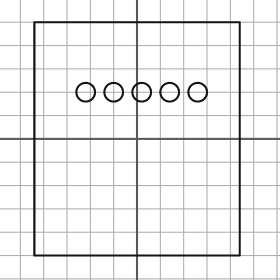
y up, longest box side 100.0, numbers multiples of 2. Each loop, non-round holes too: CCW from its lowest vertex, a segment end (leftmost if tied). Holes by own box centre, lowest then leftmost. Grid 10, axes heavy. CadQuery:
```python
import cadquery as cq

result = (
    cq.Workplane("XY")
    .moveTo(-44.0, -50.0)
    .lineTo(44.0, -50.0)
    .lineTo(44.0, 50.0)
    .lineTo(-44.0, 50.0)
    .close()
    .moveTo(-22.0, 20.0)
    .circle(4.0)
    .moveTo(-10.0, 20.0)
    .circle(4.0)
    .moveTo(2.0, 20.0)
    .circle(4.0)
    .moveTo(14.0, 20.0)
    .circle(4.0)
    .moveTo(26.0, 20.0)
    .circle(4.0)
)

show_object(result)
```